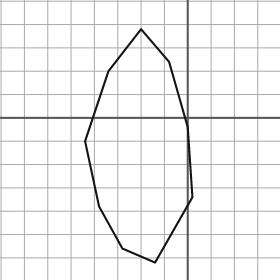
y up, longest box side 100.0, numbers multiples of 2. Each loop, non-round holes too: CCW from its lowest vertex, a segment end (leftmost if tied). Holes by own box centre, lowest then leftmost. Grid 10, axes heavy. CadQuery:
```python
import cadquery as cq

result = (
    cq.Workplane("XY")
    .moveTo(-14.0, -62.0)
    .lineTo(2.0, -34.0)
    .lineTo(0.0, -4.0)
    .lineTo(-8.0, 24.0)
    .lineTo(-20.0, 38.0)
    .lineTo(-34.0, 20.0)
    .lineTo(-44.0, -10.0)
    .lineTo(-38.0, -38.0)
    .lineTo(-28.0, -56.0)
    .close()
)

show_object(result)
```